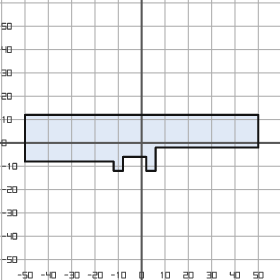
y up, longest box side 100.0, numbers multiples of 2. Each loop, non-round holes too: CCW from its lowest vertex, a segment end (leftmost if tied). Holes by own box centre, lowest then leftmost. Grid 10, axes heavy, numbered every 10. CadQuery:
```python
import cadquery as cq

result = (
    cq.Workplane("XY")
    .moveTo(-12.0, -12.0)
    .lineTo(-8.0, -12.0)
    .lineTo(-8.0, -6.0)
    .lineTo(2.0, -6.0)
    .lineTo(2.0, -12.0)
    .lineTo(6.0, -12.0)
    .lineTo(6.0, -2.0)
    .lineTo(50.0, -2.0)
    .lineTo(50.0, 12.0)
    .lineTo(-50.0, 12.0)
    .lineTo(-50.0, -8.0)
    .lineTo(-12.0, -8.0)
    .close()
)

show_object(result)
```